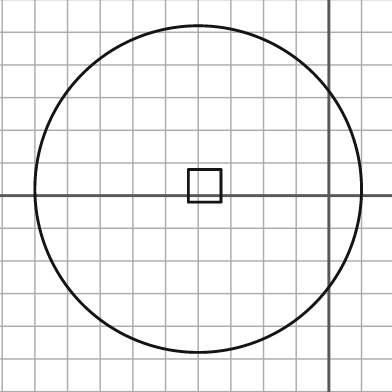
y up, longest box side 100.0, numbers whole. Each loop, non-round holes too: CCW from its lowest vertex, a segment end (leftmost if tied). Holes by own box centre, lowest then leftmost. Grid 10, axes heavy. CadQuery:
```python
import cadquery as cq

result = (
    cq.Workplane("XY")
    .moveTo(-40.0, 2.0)
    .circle(50.0)
    .moveTo(-43.0, -2.0)
    .lineTo(-33.0, -2.0)
    .lineTo(-33.0, 8.0)
    .lineTo(-43.0, 8.0)
    .close()
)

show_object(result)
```